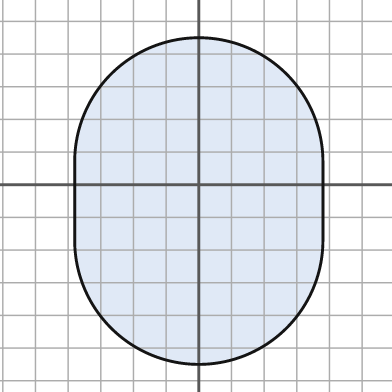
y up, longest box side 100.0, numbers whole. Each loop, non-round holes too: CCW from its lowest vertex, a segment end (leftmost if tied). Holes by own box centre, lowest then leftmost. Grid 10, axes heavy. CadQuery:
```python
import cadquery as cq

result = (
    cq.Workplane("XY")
    .moveTo(-38.0, -17.0)
    .threePointArc((0.0, -55.0), (38.0, -17.0))
    .lineTo(38.0, 7.0)
    .threePointArc((0.0, 45.0), (-38.0, 7.0))
    .close()
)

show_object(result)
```